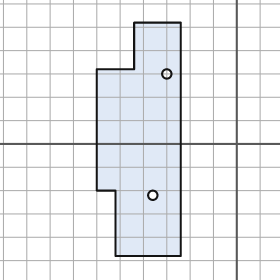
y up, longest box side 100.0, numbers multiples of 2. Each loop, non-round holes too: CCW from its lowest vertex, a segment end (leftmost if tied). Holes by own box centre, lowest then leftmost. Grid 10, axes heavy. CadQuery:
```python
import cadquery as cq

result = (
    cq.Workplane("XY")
    .moveTo(-52.0, -48.0)
    .lineTo(-24.0, -48.0)
    .lineTo(-24.0, 52.0)
    .lineTo(-44.0, 52.0)
    .lineTo(-44.0, 32.0)
    .lineTo(-60.0, 32.0)
    .lineTo(-60.0, -20.0)
    .lineTo(-52.0, -20.0)
    .close()
    .moveTo(-36.0, -22.0)
    .circle(2.0)
    .moveTo(-30.0, 30.0)
    .circle(2.0)
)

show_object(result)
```